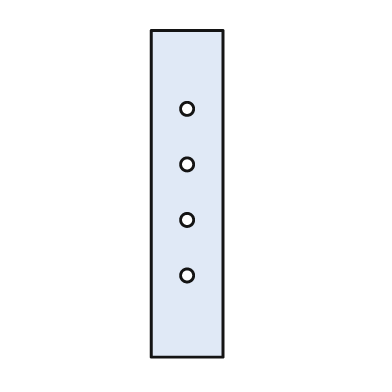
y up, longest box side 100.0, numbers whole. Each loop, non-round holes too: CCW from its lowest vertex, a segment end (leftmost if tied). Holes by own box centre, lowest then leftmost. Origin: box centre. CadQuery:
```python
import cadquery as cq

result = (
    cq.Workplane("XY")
    .moveTo(-11.0, -50.0)
    .lineTo(11.0, -50.0)
    .lineTo(11.0, 50.0)
    .lineTo(-11.0, 50.0)
    .close()
    .moveTo(0.0, -25.0)
    .circle(2.0)
    .moveTo(0.0, -8.0)
    .circle(2.0)
    .moveTo(0.0, 9.0)
    .circle(2.0)
    .moveTo(0.0, 26.0)
    .circle(2.0)
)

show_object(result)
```